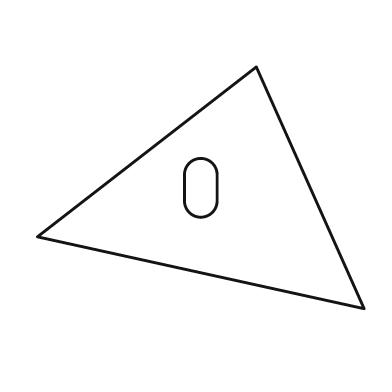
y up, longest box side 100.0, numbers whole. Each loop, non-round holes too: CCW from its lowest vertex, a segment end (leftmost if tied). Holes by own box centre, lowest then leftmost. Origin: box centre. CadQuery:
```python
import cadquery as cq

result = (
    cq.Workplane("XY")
    .moveTo(50.0, -37.0)
    .lineTo(17.0, 37.0)
    .lineTo(-50.0, -15.0)
    .close()
    .moveTo(-5.0, -4.0)
    .threePointArc((0.0, -9.0), (5.0, -4.0))
    .lineTo(5.0, 4.0)
    .threePointArc((0.0, 9.0), (-5.0, 4.0))
    .close()
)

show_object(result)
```